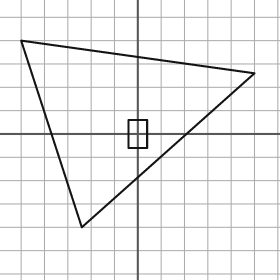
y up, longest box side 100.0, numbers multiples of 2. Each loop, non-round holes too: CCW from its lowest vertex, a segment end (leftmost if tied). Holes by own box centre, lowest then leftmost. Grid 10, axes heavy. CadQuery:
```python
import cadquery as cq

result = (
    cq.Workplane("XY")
    .moveTo(-24.0, -40.0)
    .lineTo(50.0, 26.0)
    .lineTo(-50.0, 40.0)
    .close()
    .moveTo(-4.0, -6.0)
    .lineTo(4.0, -6.0)
    .lineTo(4.0, 6.0)
    .lineTo(-4.0, 6.0)
    .close()
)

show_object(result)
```